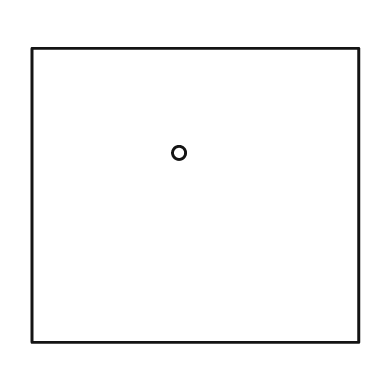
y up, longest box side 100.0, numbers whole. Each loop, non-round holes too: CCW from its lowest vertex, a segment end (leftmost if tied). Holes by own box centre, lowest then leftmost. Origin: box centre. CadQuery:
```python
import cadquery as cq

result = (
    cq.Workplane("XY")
    .moveTo(-50.0, -45.0)
    .lineTo(50.0, -45.0)
    .lineTo(50.0, 45.0)
    .lineTo(-50.0, 45.0)
    .close()
    .moveTo(-5.0, 13.0)
    .circle(2.0)
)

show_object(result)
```